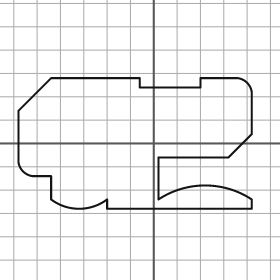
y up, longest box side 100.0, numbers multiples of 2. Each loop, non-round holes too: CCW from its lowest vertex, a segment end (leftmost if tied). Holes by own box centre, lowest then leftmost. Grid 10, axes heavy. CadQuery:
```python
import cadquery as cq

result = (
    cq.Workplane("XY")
    .moveTo(-20.0, -28.0)
    .lineTo(42.0, -28.0)
    .lineTo(42.0, -24.0)
    .threePointArc((22.0, -18.0), (2.0, -24.0))
    .lineTo(2.0, -6.0)
    .lineTo(32.0, -6.0)
    .lineTo(42.0, 4.0)
    .lineTo(42.0, 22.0)
    .threePointArc((40.0, 26.0), (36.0, 28.0))
    .lineTo(20.0, 28.0)
    .lineTo(20.0, 24.0)
    .lineTo(-6.0, 24.0)
    .lineTo(-6.0, 28.0)
    .lineTo(-44.0, 28.0)
    .lineTo(-58.0, 14.0)
    .lineTo(-58.0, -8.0)
    .threePointArc((-56.0, -12.0), (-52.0, -14.0))
    .lineTo(-44.0, -14.0)
    .lineTo(-44.0, -24.0)
    .threePointArc((-32.0, -28.0), (-20.0, -24.0))
    .close()
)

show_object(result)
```